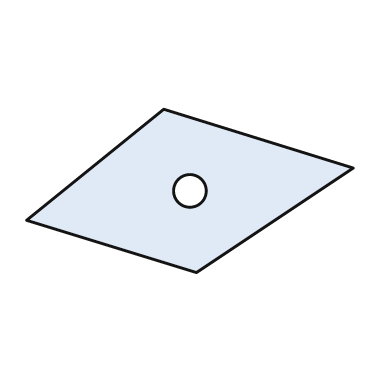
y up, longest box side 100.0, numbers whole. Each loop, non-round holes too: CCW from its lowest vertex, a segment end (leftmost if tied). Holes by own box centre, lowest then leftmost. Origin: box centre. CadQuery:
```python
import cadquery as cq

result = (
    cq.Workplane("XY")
    .moveTo(2.0, -25.0)
    .lineTo(50.0, 7.0)
    .lineTo(-8.0, 25.0)
    .lineTo(-50.0, -9.0)
    .close()
    .moveTo(0.0, 0.0)
    .circle(5.0)
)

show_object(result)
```